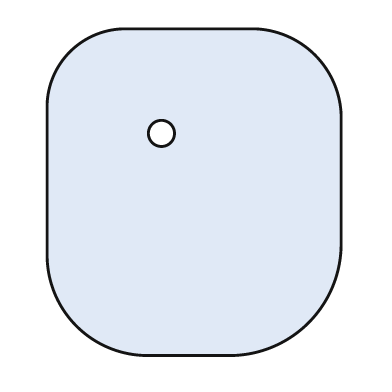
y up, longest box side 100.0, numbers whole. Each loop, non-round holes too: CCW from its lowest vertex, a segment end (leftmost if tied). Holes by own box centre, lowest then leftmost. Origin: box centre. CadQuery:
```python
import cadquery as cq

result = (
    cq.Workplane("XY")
    .moveTo(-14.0, -50.0)
    .lineTo(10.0, -50.0)
    .threePointArc((35.0, -40.0), (45.0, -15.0))
    .lineTo(45.0, 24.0)
    .threePointArc((37.0, 42.0), (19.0, 50.0))
    .lineTo(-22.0, 50.0)
    .threePointArc((-38.0, 43.0), (-45.0, 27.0))
    .lineTo(-45.0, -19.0)
    .threePointArc((-36.0, -41.0), (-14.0, -50.0))
    .close()
    .moveTo(-10.0, 18.0)
    .circle(4.0)
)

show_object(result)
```